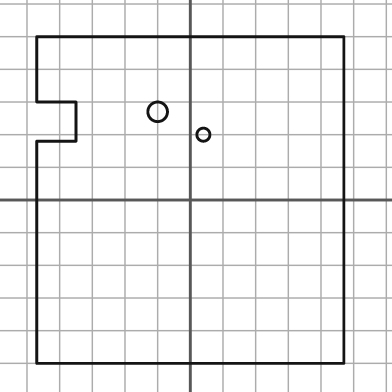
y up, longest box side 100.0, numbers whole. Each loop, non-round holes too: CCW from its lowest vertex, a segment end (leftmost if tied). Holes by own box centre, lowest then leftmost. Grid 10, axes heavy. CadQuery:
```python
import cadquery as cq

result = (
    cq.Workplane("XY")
    .moveTo(-47.0, -50.0)
    .lineTo(47.0, -50.0)
    .lineTo(47.0, 50.0)
    .lineTo(-47.0, 50.0)
    .lineTo(-47.0, 30.0)
    .lineTo(-35.0, 30.0)
    .lineTo(-35.0, 18.0)
    .lineTo(-47.0, 18.0)
    .close()
    .moveTo(4.0, 20.0)
    .circle(2.0)
    .moveTo(-10.0, 27.0)
    .circle(3.0)
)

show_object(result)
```